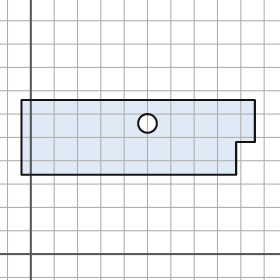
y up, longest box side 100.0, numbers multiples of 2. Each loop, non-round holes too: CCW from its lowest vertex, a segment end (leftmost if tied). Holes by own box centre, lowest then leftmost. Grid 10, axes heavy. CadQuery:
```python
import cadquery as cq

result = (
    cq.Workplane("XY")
    .moveTo(-4.0, 34.0)
    .lineTo(88.0, 34.0)
    .lineTo(88.0, 48.0)
    .lineTo(96.0, 48.0)
    .lineTo(96.0, 66.0)
    .lineTo(-4.0, 66.0)
    .close()
    .moveTo(50.0, 56.0)
    .circle(4.0)
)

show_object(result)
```